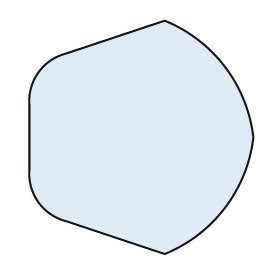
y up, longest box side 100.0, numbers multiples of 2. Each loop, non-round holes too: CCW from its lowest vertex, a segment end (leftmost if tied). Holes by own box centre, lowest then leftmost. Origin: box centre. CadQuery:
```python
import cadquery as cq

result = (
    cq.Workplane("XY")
    .moveTo(10.0, -50.0)
    .threePointArc((36.0, -30.0), (48.0, 0.0))
    .threePointArc((36.0, 30.0), (10.0, 50.0))
    .lineTo(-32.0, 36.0)
    .threePointArc((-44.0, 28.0), (-48.0, 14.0))
    .lineTo(-48.0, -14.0)
    .threePointArc((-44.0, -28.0), (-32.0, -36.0))
    .close()
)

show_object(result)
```